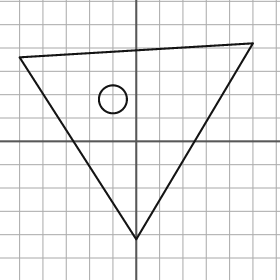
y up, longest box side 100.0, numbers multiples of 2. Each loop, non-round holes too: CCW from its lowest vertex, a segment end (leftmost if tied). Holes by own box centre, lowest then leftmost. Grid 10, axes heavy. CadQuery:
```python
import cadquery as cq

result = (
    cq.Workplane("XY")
    .moveTo(0.0, -42.0)
    .lineTo(50.0, 42.0)
    .lineTo(-50.0, 36.0)
    .close()
    .moveTo(-10.0, 18.0)
    .circle(6.0)
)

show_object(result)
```